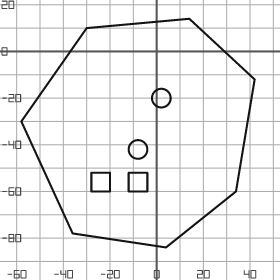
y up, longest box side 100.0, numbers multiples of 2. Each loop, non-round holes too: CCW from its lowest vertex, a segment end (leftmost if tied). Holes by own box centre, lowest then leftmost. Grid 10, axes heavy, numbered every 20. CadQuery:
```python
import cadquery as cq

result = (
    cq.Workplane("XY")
    .moveTo(4.0, -84.0)
    .lineTo(34.0, -60.0)
    .lineTo(42.0, -12.0)
    .lineTo(14.0, 14.0)
    .lineTo(-30.0, 10.0)
    .lineTo(-58.0, -30.0)
    .lineTo(-36.0, -78.0)
    .close()
    .moveTo(-28.0, -60.0)
    .lineTo(-20.0, -60.0)
    .lineTo(-20.0, -52.0)
    .lineTo(-28.0, -52.0)
    .close()
    .moveTo(-12.0, -60.0)
    .lineTo(-4.0, -60.0)
    .lineTo(-4.0, -52.0)
    .lineTo(-12.0, -52.0)
    .close()
    .moveTo(-8.0, -42.0)
    .circle(4.0)
    .moveTo(2.0, -20.0)
    .circle(4.0)
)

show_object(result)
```